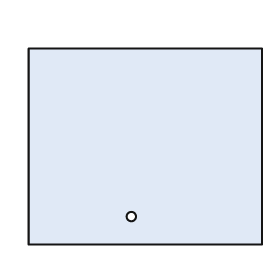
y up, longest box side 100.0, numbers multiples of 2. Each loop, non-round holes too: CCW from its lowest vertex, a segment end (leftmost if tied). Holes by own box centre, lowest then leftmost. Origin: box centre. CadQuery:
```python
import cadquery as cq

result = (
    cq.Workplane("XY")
    .moveTo(-50.0, -42.0)
    .lineTo(50.0, -42.0)
    .lineTo(50.0, 42.0)
    .lineTo(-50.0, 42.0)
    .close()
    .moveTo(-6.0, -30.0)
    .circle(2.0)
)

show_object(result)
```